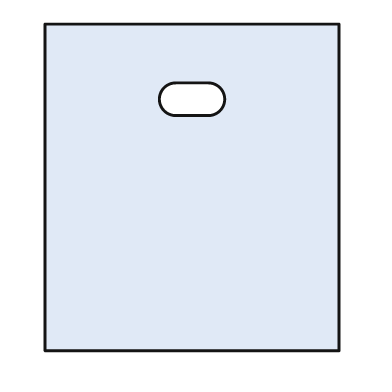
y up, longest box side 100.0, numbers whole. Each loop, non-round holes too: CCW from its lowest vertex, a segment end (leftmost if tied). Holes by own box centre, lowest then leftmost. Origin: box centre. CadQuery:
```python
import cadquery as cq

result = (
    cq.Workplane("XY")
    .moveTo(-45.0, -50.0)
    .lineTo(45.0, -50.0)
    .lineTo(45.0, 50.0)
    .lineTo(-45.0, 50.0)
    .close()
    .moveTo(-5.0, 22.0)
    .lineTo(5.0, 22.0)
    .threePointArc((10.0, 27.0), (5.0, 32.0))
    .lineTo(-5.0, 32.0)
    .threePointArc((-10.0, 27.0), (-5.0, 22.0))
    .close()
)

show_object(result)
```